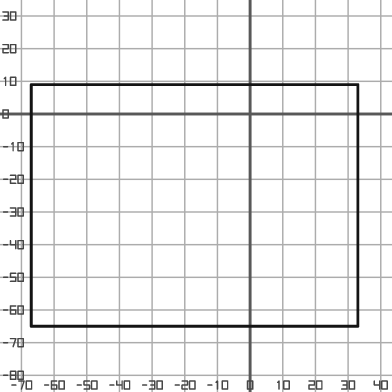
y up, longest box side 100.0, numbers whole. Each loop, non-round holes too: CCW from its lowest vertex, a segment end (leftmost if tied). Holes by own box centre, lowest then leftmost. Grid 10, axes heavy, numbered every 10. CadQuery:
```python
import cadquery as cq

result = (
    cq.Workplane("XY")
    .moveTo(-67.0, -65.0)
    .lineTo(33.0, -65.0)
    .lineTo(33.0, 9.0)
    .lineTo(-67.0, 9.0)
    .close()
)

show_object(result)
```